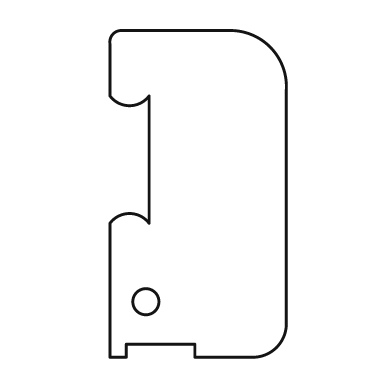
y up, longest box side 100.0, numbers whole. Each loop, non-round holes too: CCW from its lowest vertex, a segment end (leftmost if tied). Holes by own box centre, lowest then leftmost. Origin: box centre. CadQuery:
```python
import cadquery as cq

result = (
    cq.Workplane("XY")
    .moveTo(-27.0, -50.0)
    .lineTo(-22.0, -50.0)
    .lineTo(-22.0, -46.0)
    .lineTo(-1.0, -46.0)
    .lineTo(-1.0, -50.0)
    .lineTo(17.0, -50.0)
    .threePointArc((24.0, -47.0), (27.0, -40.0))
    .lineTo(27.0, 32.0)
    .threePointArc((22.0, 45.0), (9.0, 50.0))
    .lineTo(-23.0, 50.0)
    .threePointArc((-26.0, 49.0), (-27.0, 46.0))
    .lineTo(-27.0, 30.0)
    .threePointArc((-21.0, 27.0), (-15.0, 30.0))
    .lineTo(-15.0, -9.0)
    .threePointArc((-21.0, -6.0), (-27.0, -9.0))
    .close()
    .moveTo(-16.0, -33.0)
    .circle(4.0)
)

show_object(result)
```